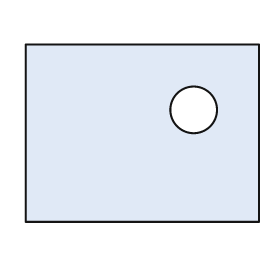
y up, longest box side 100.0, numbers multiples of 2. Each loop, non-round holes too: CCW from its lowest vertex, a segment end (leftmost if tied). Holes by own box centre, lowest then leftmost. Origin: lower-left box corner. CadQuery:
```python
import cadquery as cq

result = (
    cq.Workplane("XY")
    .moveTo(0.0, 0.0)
    .lineTo(100.0, 0.0)
    .lineTo(100.0, 76.0)
    .lineTo(0.0, 76.0)
    .close()
    .moveTo(72.0, 48.0)
    .circle(10.0)
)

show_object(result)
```